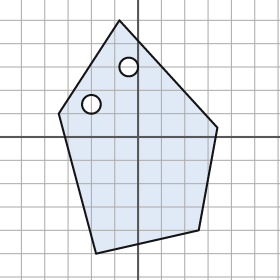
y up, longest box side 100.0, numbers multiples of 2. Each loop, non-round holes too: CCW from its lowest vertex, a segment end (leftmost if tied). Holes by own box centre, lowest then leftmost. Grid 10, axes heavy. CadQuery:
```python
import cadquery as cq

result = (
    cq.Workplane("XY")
    .moveTo(-18.0, -50.0)
    .lineTo(26.0, -40.0)
    .lineTo(34.0, 4.0)
    .lineTo(-8.0, 50.0)
    .lineTo(-34.0, 10.0)
    .close()
    .moveTo(-20.0, 14.0)
    .circle(4.0)
    .moveTo(-4.0, 30.0)
    .circle(4.0)
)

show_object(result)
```